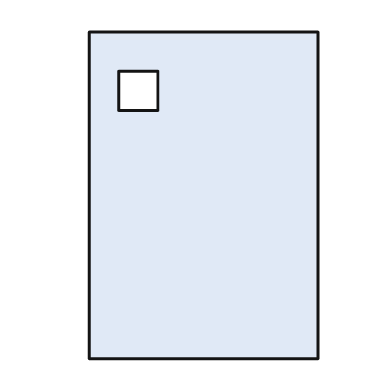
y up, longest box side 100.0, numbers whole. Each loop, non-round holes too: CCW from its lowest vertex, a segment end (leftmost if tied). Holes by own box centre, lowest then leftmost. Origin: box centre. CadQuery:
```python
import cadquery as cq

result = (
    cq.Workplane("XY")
    .moveTo(-35.0, -50.0)
    .lineTo(35.0, -50.0)
    .lineTo(35.0, 50.0)
    .lineTo(-35.0, 50.0)
    .close()
    .moveTo(-26.0, 26.0)
    .lineTo(-14.0, 26.0)
    .lineTo(-14.0, 38.0)
    .lineTo(-26.0, 38.0)
    .close()
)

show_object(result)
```